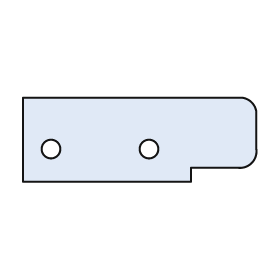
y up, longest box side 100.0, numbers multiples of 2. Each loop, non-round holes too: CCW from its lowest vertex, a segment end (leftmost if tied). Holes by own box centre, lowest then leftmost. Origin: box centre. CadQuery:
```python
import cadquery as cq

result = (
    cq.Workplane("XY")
    .moveTo(-50.0, -18.0)
    .lineTo(22.0, -18.0)
    .lineTo(22.0, -12.0)
    .lineTo(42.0, -12.0)
    .threePointArc((48.0, -10.0), (50.0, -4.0))
    .lineTo(50.0, 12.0)
    .threePointArc((48.0, 16.0), (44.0, 18.0))
    .lineTo(-50.0, 18.0)
    .close()
    .moveTo(-38.0, -4.0)
    .circle(4.0)
    .moveTo(4.0, -4.0)
    .circle(4.0)
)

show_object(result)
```